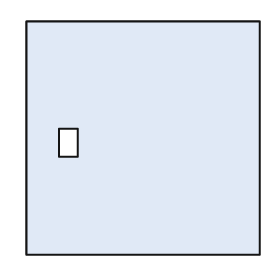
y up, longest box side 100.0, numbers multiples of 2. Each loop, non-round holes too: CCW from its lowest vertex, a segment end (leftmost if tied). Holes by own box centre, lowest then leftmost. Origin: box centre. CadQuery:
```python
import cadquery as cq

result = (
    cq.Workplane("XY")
    .moveTo(-50.0, -50.0)
    .lineTo(50.0, -50.0)
    .lineTo(50.0, 50.0)
    .lineTo(-50.0, 50.0)
    .close()
    .moveTo(-36.0, -8.0)
    .lineTo(-28.0, -8.0)
    .lineTo(-28.0, 4.0)
    .lineTo(-36.0, 4.0)
    .close()
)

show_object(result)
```